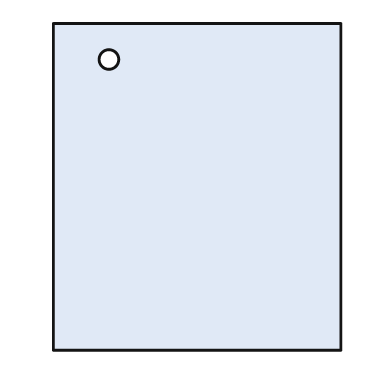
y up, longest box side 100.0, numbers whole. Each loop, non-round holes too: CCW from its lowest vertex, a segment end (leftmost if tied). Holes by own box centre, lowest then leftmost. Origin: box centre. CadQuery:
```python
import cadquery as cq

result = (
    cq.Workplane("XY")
    .moveTo(-44.0, -50.0)
    .lineTo(44.0, -50.0)
    .lineTo(44.0, 50.0)
    .lineTo(-44.0, 50.0)
    .close()
    .moveTo(-27.0, 39.0)
    .circle(3.0)
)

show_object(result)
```